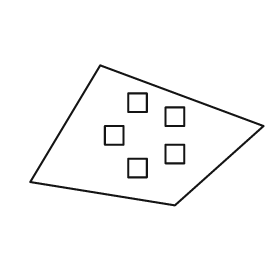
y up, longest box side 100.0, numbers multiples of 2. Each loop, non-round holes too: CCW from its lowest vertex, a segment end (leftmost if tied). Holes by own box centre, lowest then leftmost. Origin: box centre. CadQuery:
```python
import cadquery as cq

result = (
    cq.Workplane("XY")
    .moveTo(12.0, -30.0)
    .lineTo(50.0, 4.0)
    .lineTo(-20.0, 30.0)
    .lineTo(-50.0, -20.0)
    .close()
    .moveTo(-8.0, -18.0)
    .lineTo(0.0, -18.0)
    .lineTo(0.0, -10.0)
    .lineTo(-8.0, -10.0)
    .close()
    .moveTo(8.0, -12.0)
    .lineTo(16.0, -12.0)
    .lineTo(16.0, -4.0)
    .lineTo(8.0, -4.0)
    .close()
    .moveTo(-18.0, -4.0)
    .lineTo(-10.0, -4.0)
    .lineTo(-10.0, 4.0)
    .lineTo(-18.0, 4.0)
    .close()
    .moveTo(8.0, 4.0)
    .lineTo(16.0, 4.0)
    .lineTo(16.0, 12.0)
    .lineTo(8.0, 12.0)
    .close()
    .moveTo(-8.0, 10.0)
    .lineTo(0.0, 10.0)
    .lineTo(0.0, 18.0)
    .lineTo(-8.0, 18.0)
    .close()
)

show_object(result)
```